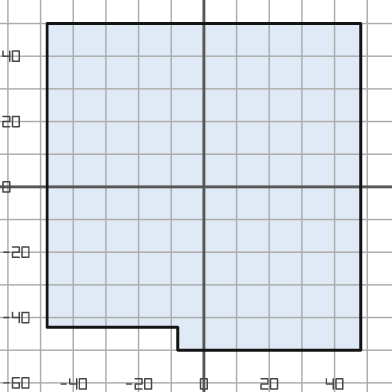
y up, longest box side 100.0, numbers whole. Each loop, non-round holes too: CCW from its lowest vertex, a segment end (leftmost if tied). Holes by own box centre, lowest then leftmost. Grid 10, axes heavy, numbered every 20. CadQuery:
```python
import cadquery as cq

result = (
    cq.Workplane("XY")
    .moveTo(-8.0, -50.0)
    .lineTo(48.0, -50.0)
    .lineTo(48.0, 50.0)
    .lineTo(-48.0, 50.0)
    .lineTo(-48.0, -43.0)
    .lineTo(-8.0, -43.0)
    .close()
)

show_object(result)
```